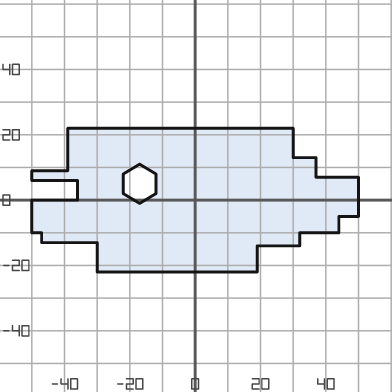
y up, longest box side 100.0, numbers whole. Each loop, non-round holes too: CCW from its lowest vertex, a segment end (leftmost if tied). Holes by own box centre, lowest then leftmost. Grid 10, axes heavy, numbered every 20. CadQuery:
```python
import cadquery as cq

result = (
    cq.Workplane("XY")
    .moveTo(-30.0, -22.0)
    .lineTo(19.0, -22.0)
    .lineTo(19.0, -14.0)
    .lineTo(32.0, -14.0)
    .lineTo(32.0, -10.0)
    .lineTo(44.0, -10.0)
    .lineTo(44.0, -5.0)
    .lineTo(50.0, -5.0)
    .lineTo(50.0, 7.0)
    .lineTo(37.0, 7.0)
    .lineTo(37.0, 13.0)
    .lineTo(30.0, 13.0)
    .lineTo(30.0, 22.0)
    .lineTo(-39.0, 22.0)
    .lineTo(-39.0, 9.0)
    .lineTo(-50.0, 9.0)
    .lineTo(-50.0, 6.0)
    .lineTo(-36.0, 6.0)
    .lineTo(-36.0, 0.0)
    .lineTo(-50.0, 0.0)
    .lineTo(-50.0, -10.0)
    .lineTo(-47.0, -10.0)
    .lineTo(-47.0, -13.0)
    .lineTo(-30.0, -13.0)
    .close()
    .moveTo(-17.0, -1.0)
    .lineTo(-12.0, 2.0)
    .lineTo(-12.0, 8.0)
    .lineTo(-17.0, 11.0)
    .lineTo(-22.0, 8.0)
    .lineTo(-22.0, 2.0)
    .close()
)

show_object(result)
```